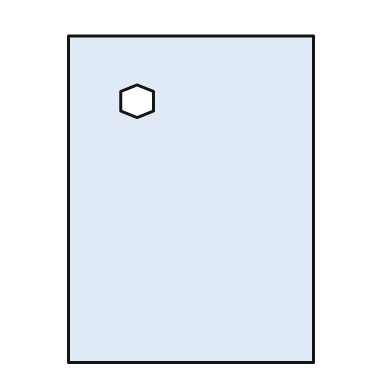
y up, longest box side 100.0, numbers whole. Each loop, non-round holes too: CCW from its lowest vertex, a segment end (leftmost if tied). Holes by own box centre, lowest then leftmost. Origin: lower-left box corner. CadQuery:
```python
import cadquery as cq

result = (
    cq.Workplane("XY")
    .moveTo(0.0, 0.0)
    .lineTo(75.0, 0.0)
    .lineTo(75.0, 100.0)
    .lineTo(0.0, 100.0)
    .close()
    .moveTo(21.0, 75.0)
    .lineTo(26.0, 77.0)
    .lineTo(26.0, 83.0)
    .lineTo(21.0, 85.0)
    .lineTo(16.0, 83.0)
    .lineTo(16.0, 77.0)
    .close()
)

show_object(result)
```